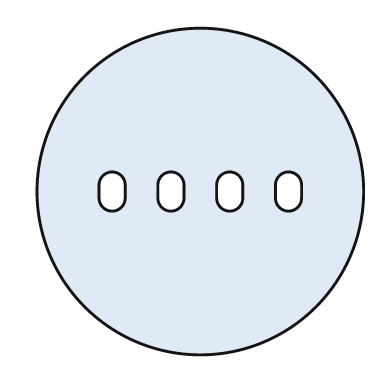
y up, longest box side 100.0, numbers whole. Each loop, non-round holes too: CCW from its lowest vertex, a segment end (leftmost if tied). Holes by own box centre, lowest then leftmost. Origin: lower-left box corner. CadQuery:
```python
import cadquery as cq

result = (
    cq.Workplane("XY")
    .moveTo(50.0, 50.0)
    .circle(50.0)
    .moveTo(19.0, 48.0)
    .threePointArc((23.0, 44.0), (27.0, 48.0))
    .lineTo(27.0, 52.0)
    .threePointArc((23.0, 56.0), (19.0, 52.0))
    .close()
    .moveTo(37.0, 48.0)
    .threePointArc((41.0, 44.0), (45.0, 48.0))
    .lineTo(45.0, 52.0)
    .threePointArc((41.0, 56.0), (37.0, 52.0))
    .close()
    .moveTo(55.0, 48.0)
    .threePointArc((59.0, 44.0), (63.0, 48.0))
    .lineTo(63.0, 52.0)
    .threePointArc((59.0, 56.0), (55.0, 52.0))
    .close()
    .moveTo(73.0, 48.0)
    .threePointArc((77.0, 44.0), (81.0, 48.0))
    .lineTo(81.0, 52.0)
    .threePointArc((77.0, 56.0), (73.0, 52.0))
    .close()
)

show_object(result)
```